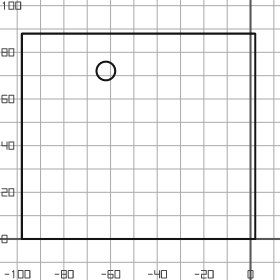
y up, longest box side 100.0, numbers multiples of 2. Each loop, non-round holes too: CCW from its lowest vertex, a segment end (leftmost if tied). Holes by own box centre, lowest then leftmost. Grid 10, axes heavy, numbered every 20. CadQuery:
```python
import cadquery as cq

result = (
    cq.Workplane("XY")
    .moveTo(-98.0, 0.0)
    .lineTo(2.0, 0.0)
    .lineTo(2.0, 88.0)
    .lineTo(-98.0, 88.0)
    .close()
    .moveTo(-62.0, 72.0)
    .circle(4.0)
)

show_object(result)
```